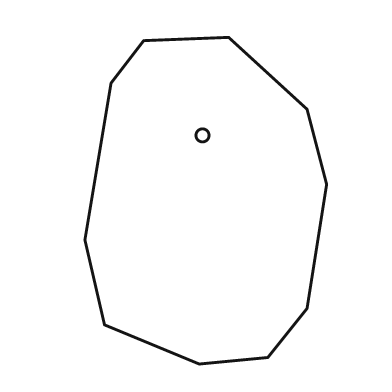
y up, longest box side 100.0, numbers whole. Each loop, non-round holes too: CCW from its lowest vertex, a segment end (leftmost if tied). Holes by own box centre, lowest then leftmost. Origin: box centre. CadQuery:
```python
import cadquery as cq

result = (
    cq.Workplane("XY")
    .moveTo(-2.0, -50.0)
    .lineTo(19.0, -48.0)
    .lineTo(31.0, -33.0)
    .lineTo(37.0, 5.0)
    .lineTo(31.0, 28.0)
    .lineTo(7.0, 50.0)
    .lineTo(-19.0, 49.0)
    .lineTo(-29.0, 36.0)
    .lineTo(-37.0, -12.0)
    .lineTo(-31.0, -38.0)
    .close()
    .moveTo(-1.0, 20.0)
    .circle(2.0)
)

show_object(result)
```